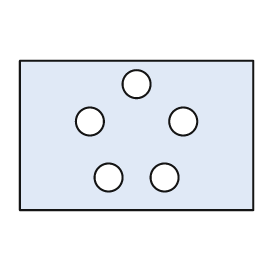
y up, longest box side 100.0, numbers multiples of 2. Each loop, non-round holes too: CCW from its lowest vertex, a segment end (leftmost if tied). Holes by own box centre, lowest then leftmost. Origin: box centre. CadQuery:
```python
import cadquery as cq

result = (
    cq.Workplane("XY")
    .moveTo(-50.0, -32.0)
    .lineTo(50.0, -32.0)
    .lineTo(50.0, 32.0)
    .lineTo(-50.0, 32.0)
    .close()
    .moveTo(-12.0, -18.0)
    .circle(6.0)
    .moveTo(12.0, -18.0)
    .circle(6.0)
    .moveTo(-20.0, 6.0)
    .circle(6.0)
    .moveTo(20.0, 6.0)
    .circle(6.0)
    .moveTo(0.0, 22.0)
    .circle(6.0)
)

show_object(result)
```